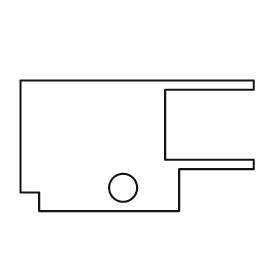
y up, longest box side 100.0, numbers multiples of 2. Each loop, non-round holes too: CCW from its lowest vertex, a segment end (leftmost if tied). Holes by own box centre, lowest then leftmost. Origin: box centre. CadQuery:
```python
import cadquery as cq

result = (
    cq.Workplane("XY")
    .moveTo(-42.0, -28.0)
    .lineTo(18.0, -28.0)
    .lineTo(18.0, -10.0)
    .lineTo(50.0, -10.0)
    .lineTo(50.0, -6.0)
    .lineTo(12.0, -6.0)
    .lineTo(12.0, 24.0)
    .lineTo(50.0, 24.0)
    .lineTo(50.0, 28.0)
    .lineTo(-50.0, 28.0)
    .lineTo(-50.0, -20.0)
    .lineTo(-42.0, -20.0)
    .close()
    .moveTo(-6.0, -18.0)
    .circle(6.0)
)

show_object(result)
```